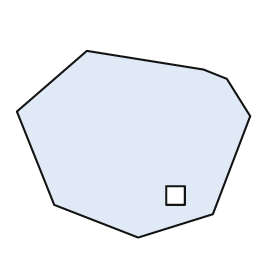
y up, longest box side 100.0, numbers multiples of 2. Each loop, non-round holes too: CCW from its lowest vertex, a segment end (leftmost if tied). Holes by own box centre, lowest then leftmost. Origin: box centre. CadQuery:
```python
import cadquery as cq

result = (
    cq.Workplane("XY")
    .moveTo(2.0, -40.0)
    .lineTo(34.0, -30.0)
    .lineTo(50.0, 12.0)
    .lineTo(40.0, 28.0)
    .lineTo(30.0, 32.0)
    .lineTo(-20.0, 40.0)
    .lineTo(-50.0, 14.0)
    .lineTo(-34.0, -26.0)
    .close()
    .moveTo(14.0, -26.0)
    .lineTo(22.0, -26.0)
    .lineTo(22.0, -18.0)
    .lineTo(14.0, -18.0)
    .close()
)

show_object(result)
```